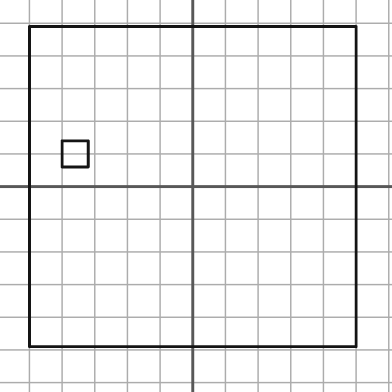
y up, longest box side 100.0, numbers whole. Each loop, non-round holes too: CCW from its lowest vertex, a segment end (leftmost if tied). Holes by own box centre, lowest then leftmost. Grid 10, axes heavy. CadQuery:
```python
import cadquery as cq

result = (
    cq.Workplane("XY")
    .moveTo(-50.0, -49.0)
    .lineTo(50.0, -49.0)
    .lineTo(50.0, 49.0)
    .lineTo(-50.0, 49.0)
    .close()
    .moveTo(-40.0, 6.0)
    .lineTo(-32.0, 6.0)
    .lineTo(-32.0, 14.0)
    .lineTo(-40.0, 14.0)
    .close()
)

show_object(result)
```